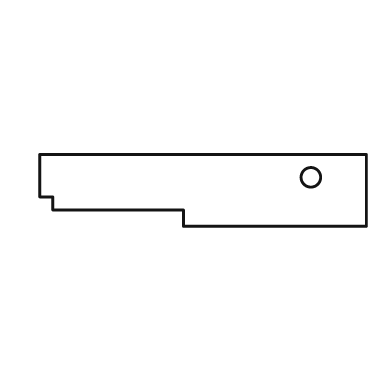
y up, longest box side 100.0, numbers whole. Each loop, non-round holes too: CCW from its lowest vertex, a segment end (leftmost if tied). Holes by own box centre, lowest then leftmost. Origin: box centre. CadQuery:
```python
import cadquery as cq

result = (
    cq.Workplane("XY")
    .moveTo(-6.0, -11.0)
    .lineTo(50.0, -11.0)
    .lineTo(50.0, 11.0)
    .lineTo(-50.0, 11.0)
    .lineTo(-50.0, -2.0)
    .lineTo(-46.0, -2.0)
    .lineTo(-46.0, -6.0)
    .lineTo(-6.0, -6.0)
    .close()
    .moveTo(33.0, 4.0)
    .circle(3.0)
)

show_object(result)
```